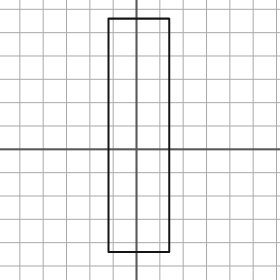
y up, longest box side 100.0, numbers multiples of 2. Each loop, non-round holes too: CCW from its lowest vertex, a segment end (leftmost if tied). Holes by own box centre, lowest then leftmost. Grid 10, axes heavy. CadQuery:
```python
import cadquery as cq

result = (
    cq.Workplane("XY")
    .moveTo(-12.0, -44.0)
    .lineTo(14.0, -44.0)
    .lineTo(14.0, 56.0)
    .lineTo(-12.0, 56.0)
    .close()
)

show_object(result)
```